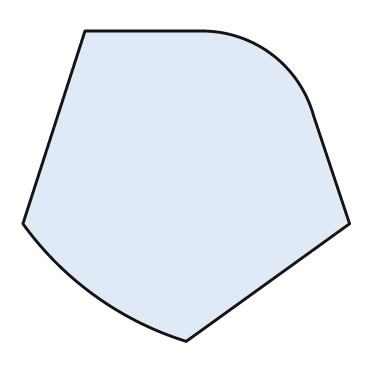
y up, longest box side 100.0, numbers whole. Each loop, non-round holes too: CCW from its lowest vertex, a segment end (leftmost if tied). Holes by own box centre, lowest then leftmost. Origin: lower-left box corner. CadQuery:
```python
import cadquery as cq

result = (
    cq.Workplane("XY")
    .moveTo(50.0, 0.0)
    .lineTo(100.0, 36.0)
    .lineTo(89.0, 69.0)
    .threePointArc((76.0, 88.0), (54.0, 95.0))
    .lineTo(19.0, 95.0)
    .lineTo(0.0, 36.0)
    .threePointArc((22.0, 14.0), (50.0, 0.0))
    .close()
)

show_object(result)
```